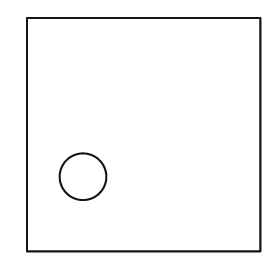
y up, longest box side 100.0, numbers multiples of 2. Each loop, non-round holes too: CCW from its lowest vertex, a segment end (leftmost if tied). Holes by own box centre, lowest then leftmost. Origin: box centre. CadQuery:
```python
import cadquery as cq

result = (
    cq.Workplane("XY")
    .moveTo(-50.0, -50.0)
    .lineTo(50.0, -50.0)
    .lineTo(50.0, 50.0)
    .lineTo(-50.0, 50.0)
    .close()
    .moveTo(-26.0, -18.0)
    .circle(10.0)
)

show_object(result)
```